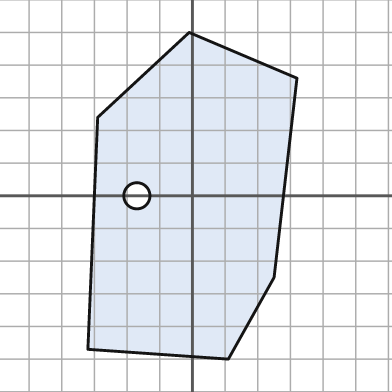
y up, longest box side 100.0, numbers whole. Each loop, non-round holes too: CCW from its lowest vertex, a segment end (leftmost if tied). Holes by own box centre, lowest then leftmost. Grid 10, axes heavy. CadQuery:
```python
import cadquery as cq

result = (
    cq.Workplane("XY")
    .moveTo(11.0, -50.0)
    .lineTo(25.0, -25.0)
    .lineTo(32.0, 36.0)
    .lineTo(-1.0, 50.0)
    .lineTo(-29.0, 24.0)
    .lineTo(-32.0, -47.0)
    .close()
    .moveTo(-17.0, 0.0)
    .circle(4.0)
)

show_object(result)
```